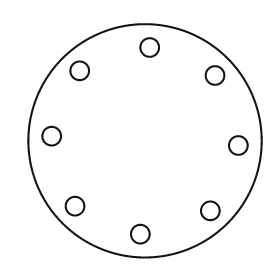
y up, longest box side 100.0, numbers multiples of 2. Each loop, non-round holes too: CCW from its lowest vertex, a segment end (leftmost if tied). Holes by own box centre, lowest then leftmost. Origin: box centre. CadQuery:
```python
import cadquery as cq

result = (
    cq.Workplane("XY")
    .moveTo(0.0, 0.0)
    .circle(50.0)
    .moveTo(-2.0, -40.0)
    .circle(4.0)
    .moveTo(28.0, -30.0)
    .circle(4.0)
    .moveTo(-30.0, -28.0)
    .circle(4.0)
    .moveTo(40.0, -2.0)
    .circle(4.0)
    .moveTo(-40.0, 2.0)
    .circle(4.0)
    .moveTo(30.0, 28.0)
    .circle(4.0)
    .moveTo(-28.0, 30.0)
    .circle(4.0)
    .moveTo(2.0, 40.0)
    .circle(4.0)
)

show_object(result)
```